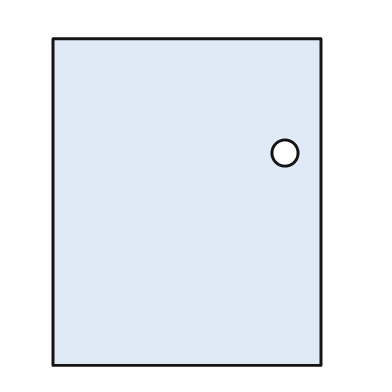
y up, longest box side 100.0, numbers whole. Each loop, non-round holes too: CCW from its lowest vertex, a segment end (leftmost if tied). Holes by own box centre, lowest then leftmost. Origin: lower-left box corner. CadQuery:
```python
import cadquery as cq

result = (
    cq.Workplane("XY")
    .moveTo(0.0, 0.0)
    .lineTo(82.0, 0.0)
    .lineTo(82.0, 100.0)
    .lineTo(0.0, 100.0)
    .close()
    .moveTo(71.0, 65.0)
    .circle(4.0)
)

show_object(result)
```